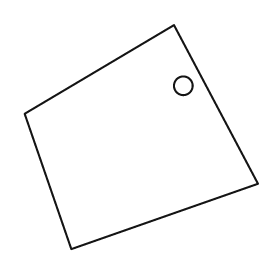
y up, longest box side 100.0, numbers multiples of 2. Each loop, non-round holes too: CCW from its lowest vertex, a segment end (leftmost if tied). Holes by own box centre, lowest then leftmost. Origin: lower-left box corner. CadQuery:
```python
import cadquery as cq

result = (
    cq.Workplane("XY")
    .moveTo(20.0, 0.0)
    .lineTo(100.0, 28.0)
    .lineTo(64.0, 96.0)
    .lineTo(0.0, 58.0)
    .close()
    .moveTo(68.0, 70.0)
    .circle(4.0)
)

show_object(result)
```